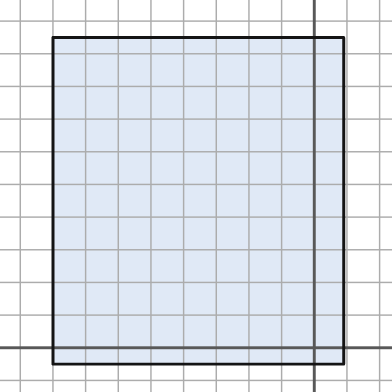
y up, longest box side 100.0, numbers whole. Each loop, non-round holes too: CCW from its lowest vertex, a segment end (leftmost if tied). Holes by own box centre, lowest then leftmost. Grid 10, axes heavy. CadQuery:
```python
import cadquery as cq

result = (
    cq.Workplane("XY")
    .moveTo(-80.0, -5.0)
    .lineTo(9.0, -5.0)
    .lineTo(9.0, 95.0)
    .lineTo(-80.0, 95.0)
    .close()
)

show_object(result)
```